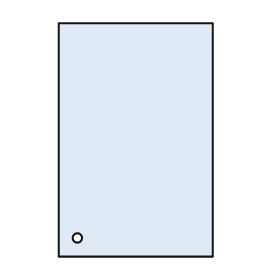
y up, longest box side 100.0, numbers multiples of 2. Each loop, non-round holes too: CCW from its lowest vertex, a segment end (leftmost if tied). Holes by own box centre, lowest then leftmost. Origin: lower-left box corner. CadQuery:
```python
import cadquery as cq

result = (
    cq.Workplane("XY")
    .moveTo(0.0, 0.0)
    .lineTo(66.0, 0.0)
    .lineTo(66.0, 100.0)
    .lineTo(0.0, 100.0)
    .close()
    .moveTo(8.0, 8.0)
    .circle(2.0)
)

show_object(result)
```